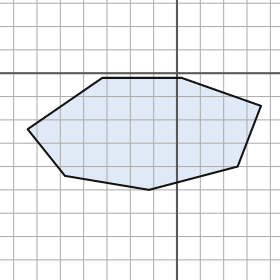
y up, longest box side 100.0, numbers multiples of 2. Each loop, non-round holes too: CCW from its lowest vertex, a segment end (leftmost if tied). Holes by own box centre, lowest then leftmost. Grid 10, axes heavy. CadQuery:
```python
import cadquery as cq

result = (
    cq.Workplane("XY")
    .moveTo(-12.0, -50.0)
    .lineTo(26.0, -40.0)
    .lineTo(36.0, -14.0)
    .lineTo(2.0, -2.0)
    .lineTo(-32.0, -2.0)
    .lineTo(-64.0, -24.0)
    .lineTo(-48.0, -44.0)
    .close()
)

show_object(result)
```